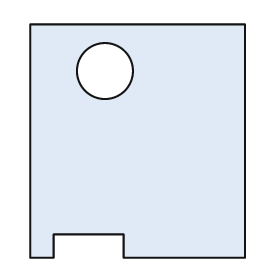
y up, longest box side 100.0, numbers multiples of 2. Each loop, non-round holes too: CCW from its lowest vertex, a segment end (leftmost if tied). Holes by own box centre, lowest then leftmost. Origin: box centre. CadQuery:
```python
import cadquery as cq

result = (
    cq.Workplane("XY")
    .moveTo(-46.0, -50.0)
    .lineTo(-36.0, -50.0)
    .lineTo(-36.0, -40.0)
    .lineTo(-6.0, -40.0)
    .lineTo(-6.0, -50.0)
    .lineTo(46.0, -50.0)
    .lineTo(46.0, 50.0)
    .lineTo(-46.0, 50.0)
    .close()
    .moveTo(-14.0, 30.0)
    .circle(12.0)
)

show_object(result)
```